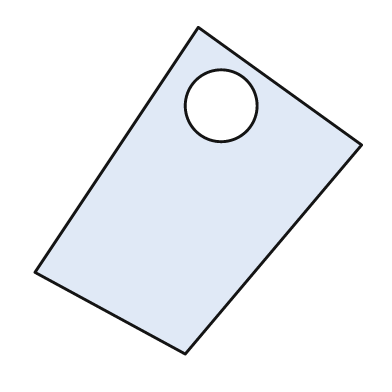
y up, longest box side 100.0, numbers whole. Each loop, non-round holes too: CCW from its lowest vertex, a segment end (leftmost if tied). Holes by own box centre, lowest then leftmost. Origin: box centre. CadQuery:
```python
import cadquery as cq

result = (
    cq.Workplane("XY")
    .moveTo(-4.0, -50.0)
    .lineTo(50.0, 14.0)
    .lineTo(0.0, 50.0)
    .lineTo(-50.0, -25.0)
    .close()
    .moveTo(7.0, 26.0)
    .circle(11.0)
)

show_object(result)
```